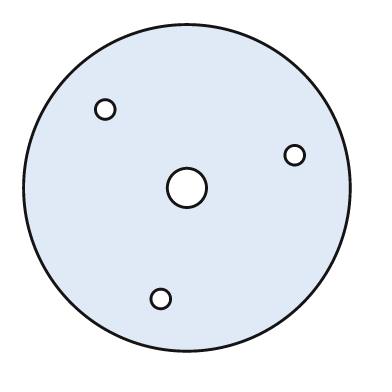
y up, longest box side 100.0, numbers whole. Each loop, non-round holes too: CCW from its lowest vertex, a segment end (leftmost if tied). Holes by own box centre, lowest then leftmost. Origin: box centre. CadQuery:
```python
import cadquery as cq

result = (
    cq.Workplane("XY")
    .moveTo(0.0, 0.0)
    .circle(50.0)
    .moveTo(-8.0, -34.0)
    .circle(3.0)
    .moveTo(0.0, 0.0)
    .circle(6.0)
    .moveTo(33.0, 10.0)
    .circle(3.0)
    .moveTo(-25.0, 24.0)
    .circle(3.0)
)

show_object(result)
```